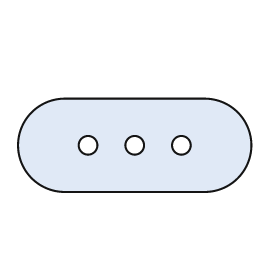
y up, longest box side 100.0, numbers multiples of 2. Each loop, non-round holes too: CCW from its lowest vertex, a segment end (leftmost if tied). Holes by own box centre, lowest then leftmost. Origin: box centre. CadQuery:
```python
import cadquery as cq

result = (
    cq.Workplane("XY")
    .moveTo(-30.0, -20.0)
    .lineTo(30.0, -20.0)
    .threePointArc((50.0, 0.0), (30.0, 20.0))
    .lineTo(-30.0, 20.0)
    .threePointArc((-50.0, 0.0), (-30.0, -20.0))
    .close()
    .moveTo(-20.0, 0.0)
    .circle(4.0)
    .moveTo(0.0, 0.0)
    .circle(4.0)
    .moveTo(20.0, 0.0)
    .circle(4.0)
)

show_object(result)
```